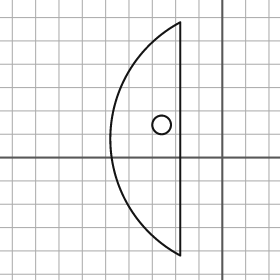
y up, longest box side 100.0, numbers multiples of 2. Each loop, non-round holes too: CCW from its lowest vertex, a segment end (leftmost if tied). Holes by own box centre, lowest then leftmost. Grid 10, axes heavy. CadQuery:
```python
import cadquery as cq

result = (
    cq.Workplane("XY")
    .moveTo(-18.0, -42.0)
    .lineTo(-18.0, 58.0)
    .threePointArc((-48.0, 8.0), (-18.0, -42.0))
    .close()
    .moveTo(-26.0, 14.0)
    .circle(4.0)
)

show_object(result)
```